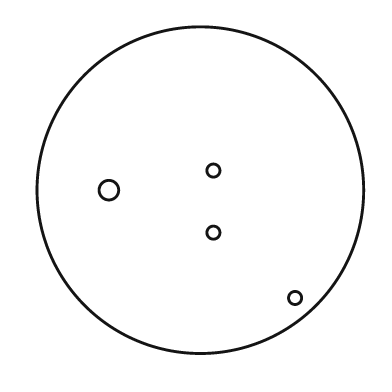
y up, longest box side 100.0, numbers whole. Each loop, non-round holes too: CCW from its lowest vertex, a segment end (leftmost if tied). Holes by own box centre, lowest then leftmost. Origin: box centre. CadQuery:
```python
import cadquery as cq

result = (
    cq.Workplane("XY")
    .moveTo(0.0, 0.0)
    .circle(50.0)
    .moveTo(29.0, -33.0)
    .circle(2.0)
    .moveTo(4.0, -13.0)
    .circle(2.0)
    .moveTo(-28.0, 0.0)
    .circle(3.0)
    .moveTo(4.0, 6.0)
    .circle(2.0)
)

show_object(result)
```